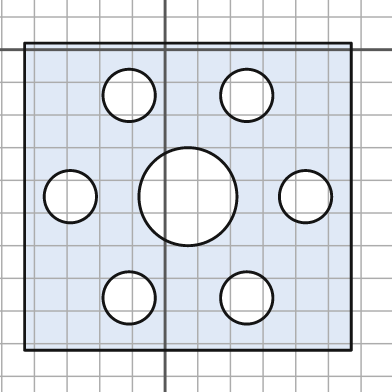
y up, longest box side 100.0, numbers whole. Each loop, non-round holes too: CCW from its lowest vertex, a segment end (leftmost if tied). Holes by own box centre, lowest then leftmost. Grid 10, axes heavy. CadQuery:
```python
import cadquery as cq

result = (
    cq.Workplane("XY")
    .moveTo(-43.0, -92.0)
    .lineTo(57.0, -92.0)
    .lineTo(57.0, 2.0)
    .lineTo(-43.0, 2.0)
    .close()
    .moveTo(-11.0, -76.0)
    .circle(8.0)
    .moveTo(25.0, -76.0)
    .circle(8.0)
    .moveTo(-29.0, -45.0)
    .circle(8.0)
    .moveTo(7.0, -45.0)
    .circle(15.0)
    .moveTo(43.0, -45.0)
    .circle(8.0)
    .moveTo(-11.0, -14.0)
    .circle(8.0)
    .moveTo(25.0, -14.0)
    .circle(8.0)
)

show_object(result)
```